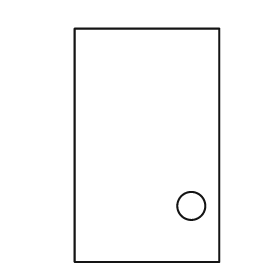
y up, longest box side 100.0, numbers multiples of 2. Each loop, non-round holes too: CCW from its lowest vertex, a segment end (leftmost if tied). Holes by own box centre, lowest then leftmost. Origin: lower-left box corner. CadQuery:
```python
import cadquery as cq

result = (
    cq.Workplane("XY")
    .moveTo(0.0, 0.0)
    .lineTo(62.0, 0.0)
    .lineTo(62.0, 100.0)
    .lineTo(0.0, 100.0)
    .close()
    .moveTo(50.0, 24.0)
    .circle(6.0)
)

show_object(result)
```